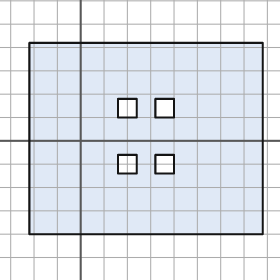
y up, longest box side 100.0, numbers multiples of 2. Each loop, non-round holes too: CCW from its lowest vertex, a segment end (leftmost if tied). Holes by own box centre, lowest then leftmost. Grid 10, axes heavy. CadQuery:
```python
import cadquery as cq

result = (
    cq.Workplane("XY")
    .moveTo(-22.0, -40.0)
    .lineTo(78.0, -40.0)
    .lineTo(78.0, 42.0)
    .lineTo(-22.0, 42.0)
    .close()
    .moveTo(16.0, -14.0)
    .lineTo(24.0, -14.0)
    .lineTo(24.0, -6.0)
    .lineTo(16.0, -6.0)
    .close()
    .moveTo(32.0, -14.0)
    .lineTo(40.0, -14.0)
    .lineTo(40.0, -6.0)
    .lineTo(32.0, -6.0)
    .close()
    .moveTo(16.0, 10.0)
    .lineTo(24.0, 10.0)
    .lineTo(24.0, 18.0)
    .lineTo(16.0, 18.0)
    .close()
    .moveTo(32.0, 10.0)
    .lineTo(40.0, 10.0)
    .lineTo(40.0, 18.0)
    .lineTo(32.0, 18.0)
    .close()
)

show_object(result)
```